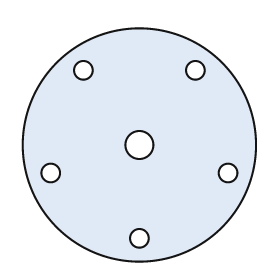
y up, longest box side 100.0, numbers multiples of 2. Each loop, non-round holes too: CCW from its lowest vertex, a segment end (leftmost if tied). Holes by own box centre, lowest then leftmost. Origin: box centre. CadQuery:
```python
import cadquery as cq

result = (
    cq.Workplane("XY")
    .moveTo(0.0, 0.0)
    .circle(50.0)
    .moveTo(0.0, -40.0)
    .circle(4.0)
    .moveTo(-38.0, -12.0)
    .circle(4.0)
    .moveTo(38.0, -12.0)
    .circle(4.0)
    .moveTo(0.0, 0.0)
    .circle(6.0)
    .moveTo(-24.0, 32.0)
    .circle(4.0)
    .moveTo(24.0, 32.0)
    .circle(4.0)
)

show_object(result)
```